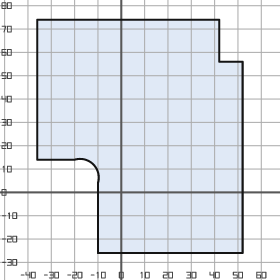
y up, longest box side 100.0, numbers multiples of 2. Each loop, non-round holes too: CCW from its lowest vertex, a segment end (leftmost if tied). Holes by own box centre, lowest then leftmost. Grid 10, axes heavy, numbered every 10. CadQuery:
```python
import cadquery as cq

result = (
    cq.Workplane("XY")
    .moveTo(-10.0, -26.0)
    .lineTo(52.0, -26.0)
    .lineTo(52.0, 56.0)
    .lineTo(42.0, 56.0)
    .lineTo(42.0, 74.0)
    .lineTo(-36.0, 74.0)
    .lineTo(-36.0, 14.0)
    .lineTo(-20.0, 14.0)
    .threePointArc((-12.0, 12.0), (-10.0, 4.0))
    .close()
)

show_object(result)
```